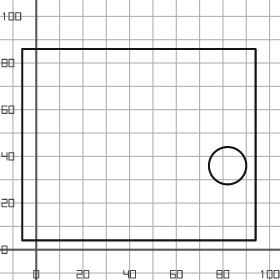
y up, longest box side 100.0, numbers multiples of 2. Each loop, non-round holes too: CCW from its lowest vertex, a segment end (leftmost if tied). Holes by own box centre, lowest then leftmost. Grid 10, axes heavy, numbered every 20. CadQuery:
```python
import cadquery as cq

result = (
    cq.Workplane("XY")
    .moveTo(-6.0, 4.0)
    .lineTo(94.0, 4.0)
    .lineTo(94.0, 86.0)
    .lineTo(-6.0, 86.0)
    .close()
    .moveTo(82.0, 36.0)
    .circle(8.0)
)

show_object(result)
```